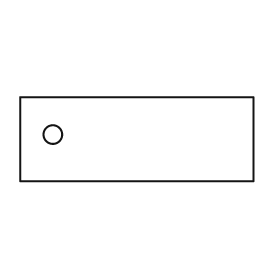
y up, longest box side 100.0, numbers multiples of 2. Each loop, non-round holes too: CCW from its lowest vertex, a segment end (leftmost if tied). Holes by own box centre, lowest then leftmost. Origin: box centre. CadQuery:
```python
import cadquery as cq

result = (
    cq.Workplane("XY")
    .moveTo(-50.0, -18.0)
    .lineTo(50.0, -18.0)
    .lineTo(50.0, 18.0)
    .lineTo(-50.0, 18.0)
    .close()
    .moveTo(-36.0, 2.0)
    .circle(4.0)
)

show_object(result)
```